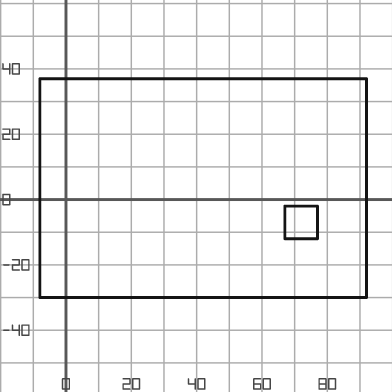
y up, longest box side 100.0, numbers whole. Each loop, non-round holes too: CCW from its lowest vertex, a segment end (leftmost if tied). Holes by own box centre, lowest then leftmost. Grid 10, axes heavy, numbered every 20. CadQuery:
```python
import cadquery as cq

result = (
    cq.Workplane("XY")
    .moveTo(-8.0, -30.0)
    .lineTo(92.0, -30.0)
    .lineTo(92.0, 37.0)
    .lineTo(-8.0, 37.0)
    .close()
    .moveTo(67.0, -12.0)
    .lineTo(77.0, -12.0)
    .lineTo(77.0, -2.0)
    .lineTo(67.0, -2.0)
    .close()
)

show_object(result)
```